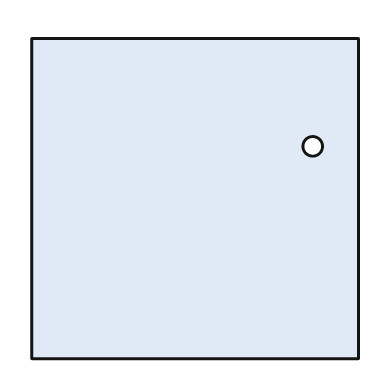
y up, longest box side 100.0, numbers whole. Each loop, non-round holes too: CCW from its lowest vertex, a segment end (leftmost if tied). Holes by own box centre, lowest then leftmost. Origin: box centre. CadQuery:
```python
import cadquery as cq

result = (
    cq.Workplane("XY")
    .moveTo(-50.0, -49.0)
    .lineTo(50.0, -49.0)
    .lineTo(50.0, 49.0)
    .lineTo(-50.0, 49.0)
    .close()
    .moveTo(36.0, 16.0)
    .circle(3.0)
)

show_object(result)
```